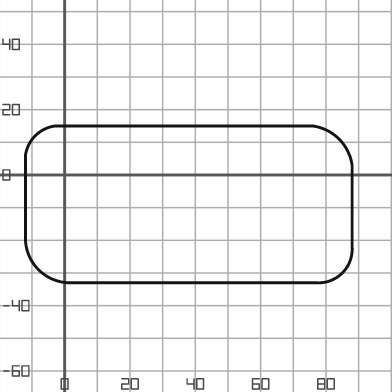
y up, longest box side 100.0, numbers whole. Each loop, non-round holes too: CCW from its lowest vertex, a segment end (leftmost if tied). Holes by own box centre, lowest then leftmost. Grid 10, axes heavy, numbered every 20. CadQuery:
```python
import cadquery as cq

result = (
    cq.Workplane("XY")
    .moveTo(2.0, -33.0)
    .lineTo(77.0, -33.0)
    .threePointArc((85.0, -30.0), (88.0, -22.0))
    .lineTo(88.0, 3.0)
    .threePointArc((84.0, 11.0), (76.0, 15.0))
    .lineTo(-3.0, 15.0)
    .threePointArc((-9.0, 12.0), (-12.0, 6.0))
    .lineTo(-12.0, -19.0)
    .threePointArc((-8.0, -29.0), (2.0, -33.0))
    .close()
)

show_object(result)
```